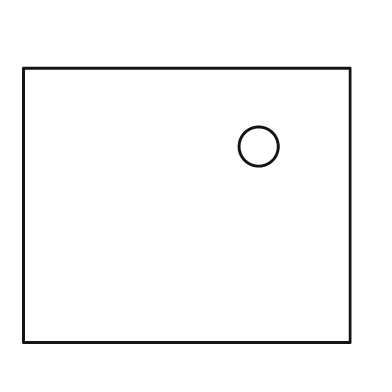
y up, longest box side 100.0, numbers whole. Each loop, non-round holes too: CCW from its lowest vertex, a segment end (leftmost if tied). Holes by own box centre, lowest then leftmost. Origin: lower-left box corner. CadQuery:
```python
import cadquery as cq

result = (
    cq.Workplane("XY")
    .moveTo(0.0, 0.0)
    .lineTo(100.0, 0.0)
    .lineTo(100.0, 84.0)
    .lineTo(0.0, 84.0)
    .close()
    .moveTo(72.0, 60.0)
    .circle(6.0)
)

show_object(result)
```